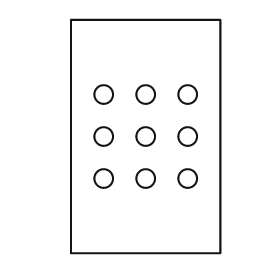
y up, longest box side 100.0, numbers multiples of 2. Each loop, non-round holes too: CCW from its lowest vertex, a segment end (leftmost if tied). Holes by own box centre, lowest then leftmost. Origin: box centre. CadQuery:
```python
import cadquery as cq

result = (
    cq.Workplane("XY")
    .moveTo(-32.0, -50.0)
    .lineTo(32.0, -50.0)
    .lineTo(32.0, 50.0)
    .lineTo(-32.0, 50.0)
    .close()
    .moveTo(-18.0, -18.0)
    .circle(4.0)
    .moveTo(0.0, -18.0)
    .circle(4.0)
    .moveTo(18.0, -18.0)
    .circle(4.0)
    .moveTo(-18.0, 0.0)
    .circle(4.0)
    .moveTo(0.0, 0.0)
    .circle(4.0)
    .moveTo(18.0, 0.0)
    .circle(4.0)
    .moveTo(-18.0, 18.0)
    .circle(4.0)
    .moveTo(0.0, 18.0)
    .circle(4.0)
    .moveTo(18.0, 18.0)
    .circle(4.0)
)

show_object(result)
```